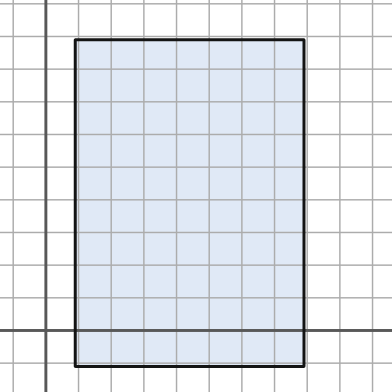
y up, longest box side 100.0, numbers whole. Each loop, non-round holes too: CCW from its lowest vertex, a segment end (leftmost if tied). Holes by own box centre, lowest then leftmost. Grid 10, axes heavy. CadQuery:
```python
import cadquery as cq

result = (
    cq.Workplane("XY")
    .moveTo(9.0, -11.0)
    .lineTo(79.0, -11.0)
    .lineTo(79.0, 89.0)
    .lineTo(9.0, 89.0)
    .close()
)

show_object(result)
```